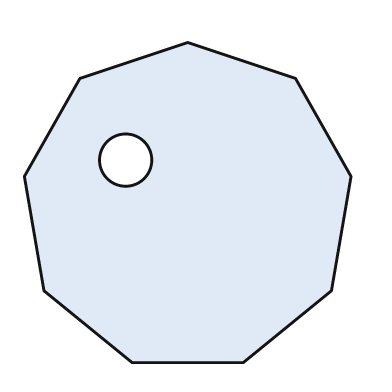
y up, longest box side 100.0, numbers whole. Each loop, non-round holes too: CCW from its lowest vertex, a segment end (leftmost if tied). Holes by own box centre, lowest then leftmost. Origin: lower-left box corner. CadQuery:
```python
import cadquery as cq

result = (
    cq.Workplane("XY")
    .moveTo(33.0, 0.0)
    .lineTo(67.0, 0.0)
    .lineTo(94.0, 22.0)
    .lineTo(100.0, 57.0)
    .lineTo(83.0, 87.0)
    .lineTo(50.0, 98.0)
    .lineTo(17.0, 87.0)
    .lineTo(0.0, 57.0)
    .lineTo(6.0, 22.0)
    .close()
    .moveTo(31.0, 62.0)
    .circle(8.0)
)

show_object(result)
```